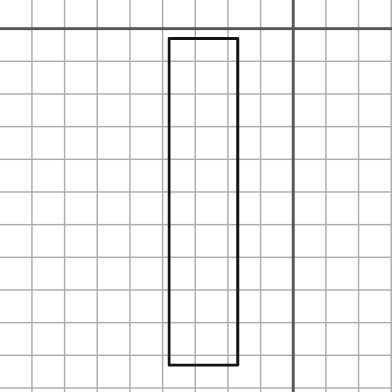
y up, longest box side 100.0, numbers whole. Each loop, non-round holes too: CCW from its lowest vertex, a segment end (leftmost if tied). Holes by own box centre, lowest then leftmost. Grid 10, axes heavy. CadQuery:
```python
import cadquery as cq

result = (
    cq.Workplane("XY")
    .moveTo(-38.0, -103.0)
    .lineTo(-17.0, -103.0)
    .lineTo(-17.0, -3.0)
    .lineTo(-38.0, -3.0)
    .close()
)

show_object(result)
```